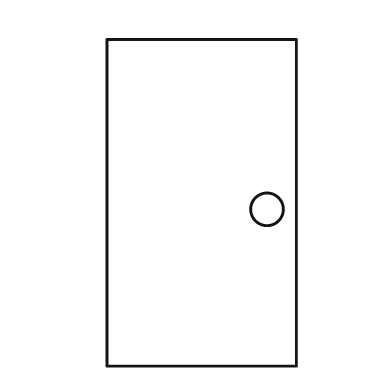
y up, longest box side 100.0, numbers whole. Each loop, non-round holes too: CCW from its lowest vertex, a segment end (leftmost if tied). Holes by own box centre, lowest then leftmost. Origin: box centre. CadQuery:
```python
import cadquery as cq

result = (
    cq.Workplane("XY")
    .moveTo(-29.0, -50.0)
    .lineTo(29.0, -50.0)
    .lineTo(29.0, 50.0)
    .lineTo(-29.0, 50.0)
    .close()
    .moveTo(20.0, -2.0)
    .circle(5.0)
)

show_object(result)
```